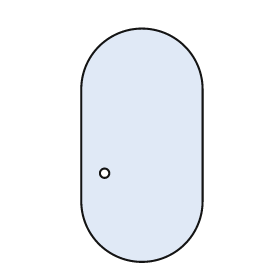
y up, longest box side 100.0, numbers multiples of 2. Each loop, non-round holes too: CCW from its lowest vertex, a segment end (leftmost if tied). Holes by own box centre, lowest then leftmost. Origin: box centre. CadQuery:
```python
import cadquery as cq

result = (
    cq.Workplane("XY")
    .moveTo(-26.0, -24.0)
    .threePointArc((0.0, -50.0), (26.0, -24.0))
    .lineTo(26.0, 24.0)
    .threePointArc((0.0, 50.0), (-26.0, 24.0))
    .close()
    .moveTo(-16.0, -12.0)
    .circle(2.0)
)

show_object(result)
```